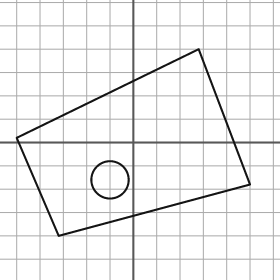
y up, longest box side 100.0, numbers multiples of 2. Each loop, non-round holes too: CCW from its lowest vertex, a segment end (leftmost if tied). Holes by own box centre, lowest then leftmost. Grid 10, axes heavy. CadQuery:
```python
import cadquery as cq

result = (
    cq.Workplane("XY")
    .moveTo(-32.0, -40.0)
    .lineTo(50.0, -18.0)
    .lineTo(28.0, 40.0)
    .lineTo(-50.0, 2.0)
    .close()
    .moveTo(-10.0, -16.0)
    .circle(8.0)
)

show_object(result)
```